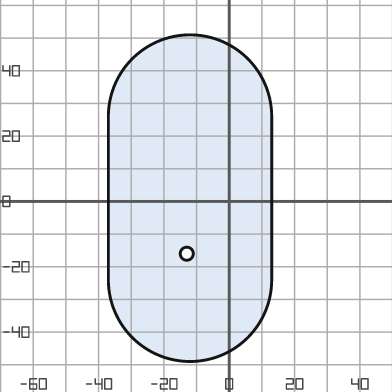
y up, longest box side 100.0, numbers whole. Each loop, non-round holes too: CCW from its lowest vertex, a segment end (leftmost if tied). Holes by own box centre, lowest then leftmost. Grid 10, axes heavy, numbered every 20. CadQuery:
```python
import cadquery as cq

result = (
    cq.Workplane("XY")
    .moveTo(-37.0, -24.0)
    .threePointArc((-12.0, -49.0), (13.0, -24.0))
    .lineTo(13.0, 26.0)
    .threePointArc((-12.0, 51.0), (-37.0, 26.0))
    .close()
    .moveTo(-13.0, -16.0)
    .circle(2.0)
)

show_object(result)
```